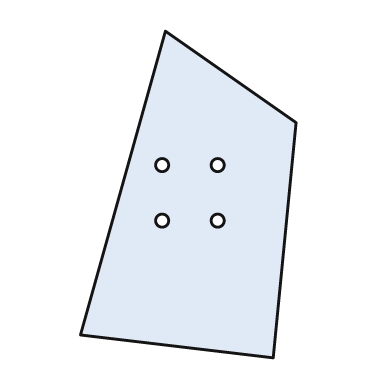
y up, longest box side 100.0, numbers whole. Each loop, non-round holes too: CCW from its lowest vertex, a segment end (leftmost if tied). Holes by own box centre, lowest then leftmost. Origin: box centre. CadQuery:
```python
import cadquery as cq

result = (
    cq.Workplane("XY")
    .moveTo(26.0, -50.0)
    .lineTo(33.0, 22.0)
    .lineTo(-7.0, 50.0)
    .lineTo(-33.0, -43.0)
    .close()
    .moveTo(-8.0, -8.0)
    .circle(2.0)
    .moveTo(9.0, -8.0)
    .circle(2.0)
    .moveTo(-8.0, 9.0)
    .circle(2.0)
    .moveTo(9.0, 9.0)
    .circle(2.0)
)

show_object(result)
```